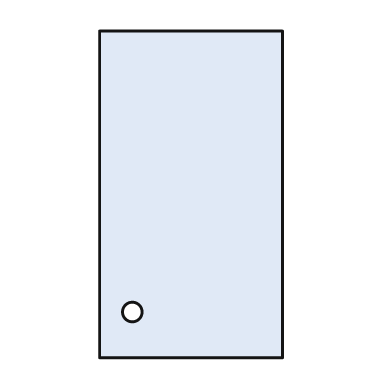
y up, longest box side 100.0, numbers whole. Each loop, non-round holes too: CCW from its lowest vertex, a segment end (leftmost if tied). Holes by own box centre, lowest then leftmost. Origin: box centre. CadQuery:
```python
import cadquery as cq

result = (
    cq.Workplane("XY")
    .moveTo(-28.0, -50.0)
    .lineTo(28.0, -50.0)
    .lineTo(28.0, 50.0)
    .lineTo(-28.0, 50.0)
    .close()
    .moveTo(-18.0, -36.0)
    .circle(3.0)
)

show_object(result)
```